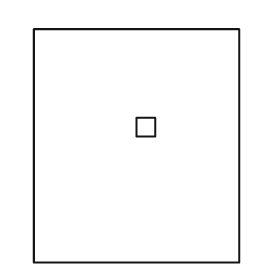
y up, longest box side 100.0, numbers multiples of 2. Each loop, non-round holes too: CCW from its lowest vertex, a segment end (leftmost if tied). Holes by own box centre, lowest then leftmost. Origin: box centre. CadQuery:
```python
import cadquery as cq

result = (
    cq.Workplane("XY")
    .moveTo(-44.0, -50.0)
    .lineTo(44.0, -50.0)
    .lineTo(44.0, 50.0)
    .lineTo(-44.0, 50.0)
    .close()
    .moveTo(0.0, 4.0)
    .lineTo(8.0, 4.0)
    .lineTo(8.0, 12.0)
    .lineTo(0.0, 12.0)
    .close()
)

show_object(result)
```